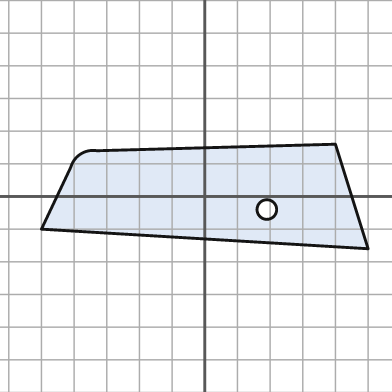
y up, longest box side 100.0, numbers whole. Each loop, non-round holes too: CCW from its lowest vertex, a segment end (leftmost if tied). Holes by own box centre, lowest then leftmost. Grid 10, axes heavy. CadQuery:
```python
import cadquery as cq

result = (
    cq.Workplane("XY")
    .moveTo(50.0, -16.0)
    .lineTo(40.0, 16.0)
    .lineTo(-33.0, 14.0)
    .threePointArc((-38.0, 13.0), (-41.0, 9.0))
    .lineTo(-50.0, -10.0)
    .close()
    .moveTo(19.0, -4.0)
    .circle(3.0)
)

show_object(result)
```